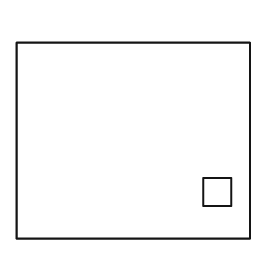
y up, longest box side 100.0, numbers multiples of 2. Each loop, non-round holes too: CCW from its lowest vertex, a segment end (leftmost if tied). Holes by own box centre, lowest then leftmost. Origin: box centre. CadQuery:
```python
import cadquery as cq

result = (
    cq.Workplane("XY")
    .moveTo(-50.0, -42.0)
    .lineTo(50.0, -42.0)
    .lineTo(50.0, 42.0)
    .lineTo(-50.0, 42.0)
    .close()
    .moveTo(30.0, -28.0)
    .lineTo(42.0, -28.0)
    .lineTo(42.0, -16.0)
    .lineTo(30.0, -16.0)
    .close()
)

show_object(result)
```